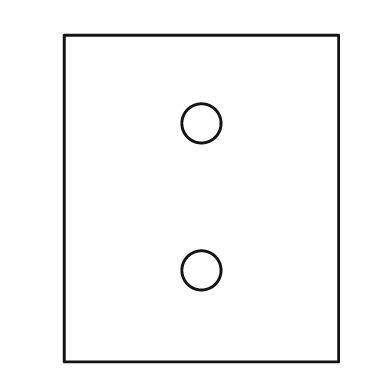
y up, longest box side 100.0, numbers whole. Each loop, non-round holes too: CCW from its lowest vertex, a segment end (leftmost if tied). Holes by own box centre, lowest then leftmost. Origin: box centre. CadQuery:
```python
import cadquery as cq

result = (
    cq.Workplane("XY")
    .moveTo(-42.0, -50.0)
    .lineTo(42.0, -50.0)
    .lineTo(42.0, 50.0)
    .lineTo(-42.0, 50.0)
    .close()
    .moveTo(0.0, -22.0)
    .circle(6.0)
    .moveTo(0.0, 23.0)
    .circle(6.0)
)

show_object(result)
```